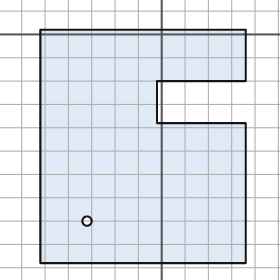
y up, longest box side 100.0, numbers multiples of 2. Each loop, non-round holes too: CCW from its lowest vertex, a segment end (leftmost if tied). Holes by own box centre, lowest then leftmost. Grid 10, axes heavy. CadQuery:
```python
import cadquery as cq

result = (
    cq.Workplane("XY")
    .moveTo(-52.0, -98.0)
    .lineTo(36.0, -98.0)
    .lineTo(36.0, -38.0)
    .lineTo(-2.0, -38.0)
    .lineTo(-2.0, -20.0)
    .lineTo(36.0, -20.0)
    .lineTo(36.0, 2.0)
    .lineTo(-52.0, 2.0)
    .close()
    .moveTo(-32.0, -80.0)
    .circle(2.0)
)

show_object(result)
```